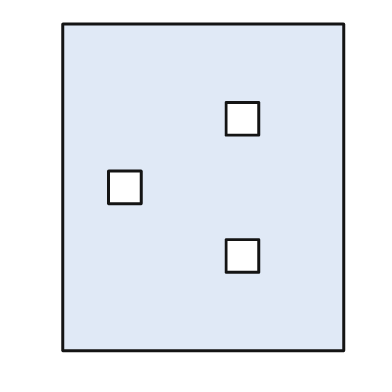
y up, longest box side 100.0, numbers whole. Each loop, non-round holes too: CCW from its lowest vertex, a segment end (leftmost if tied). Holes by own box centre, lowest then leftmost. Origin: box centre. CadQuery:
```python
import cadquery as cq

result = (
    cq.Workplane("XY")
    .moveTo(-43.0, -50.0)
    .lineTo(43.0, -50.0)
    .lineTo(43.0, 50.0)
    .lineTo(-43.0, 50.0)
    .close()
    .moveTo(7.0, -26.0)
    .lineTo(17.0, -26.0)
    .lineTo(17.0, -16.0)
    .lineTo(7.0, -16.0)
    .close()
    .moveTo(-29.0, -5.0)
    .lineTo(-19.0, -5.0)
    .lineTo(-19.0, 5.0)
    .lineTo(-29.0, 5.0)
    .close()
    .moveTo(7.0, 16.0)
    .lineTo(17.0, 16.0)
    .lineTo(17.0, 26.0)
    .lineTo(7.0, 26.0)
    .close()
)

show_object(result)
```